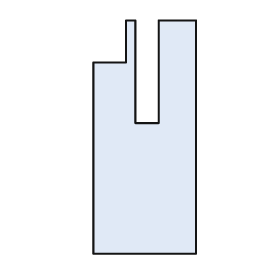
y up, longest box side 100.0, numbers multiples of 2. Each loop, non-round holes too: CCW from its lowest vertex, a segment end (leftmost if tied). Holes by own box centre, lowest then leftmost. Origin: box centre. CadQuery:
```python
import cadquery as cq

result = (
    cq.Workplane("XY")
    .moveTo(-22.0, -50.0)
    .lineTo(22.0, -50.0)
    .lineTo(22.0, 50.0)
    .lineTo(6.0, 50.0)
    .lineTo(6.0, 6.0)
    .lineTo(-4.0, 6.0)
    .lineTo(-4.0, 50.0)
    .lineTo(-8.0, 50.0)
    .lineTo(-8.0, 32.0)
    .lineTo(-22.0, 32.0)
    .close()
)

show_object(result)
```